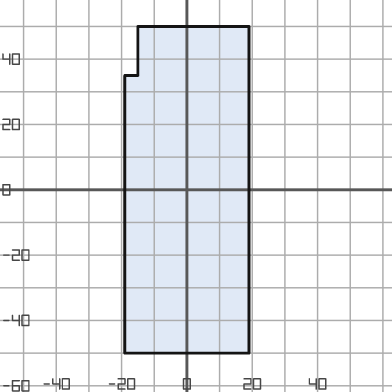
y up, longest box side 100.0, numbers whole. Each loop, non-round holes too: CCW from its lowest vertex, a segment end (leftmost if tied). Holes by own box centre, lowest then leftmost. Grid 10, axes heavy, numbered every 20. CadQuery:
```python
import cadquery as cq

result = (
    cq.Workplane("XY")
    .moveTo(-19.0, -50.0)
    .lineTo(19.0, -50.0)
    .lineTo(19.0, 50.0)
    .lineTo(-15.0, 50.0)
    .lineTo(-15.0, 35.0)
    .lineTo(-19.0, 35.0)
    .close()
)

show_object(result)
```